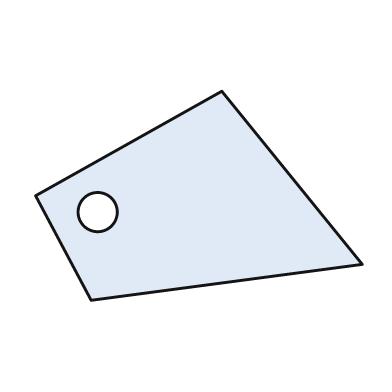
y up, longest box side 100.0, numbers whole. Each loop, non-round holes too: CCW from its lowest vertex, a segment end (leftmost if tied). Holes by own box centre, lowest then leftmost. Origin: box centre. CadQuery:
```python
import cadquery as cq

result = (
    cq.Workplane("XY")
    .moveTo(-33.0, -32.0)
    .lineTo(50.0, -21.0)
    .lineTo(7.0, 32.0)
    .lineTo(-50.0, 0.0)
    .close()
    .moveTo(-31.0, -5.0)
    .circle(6.0)
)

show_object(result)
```